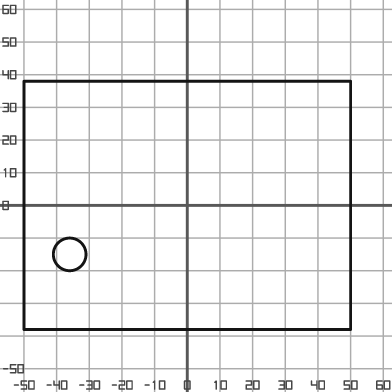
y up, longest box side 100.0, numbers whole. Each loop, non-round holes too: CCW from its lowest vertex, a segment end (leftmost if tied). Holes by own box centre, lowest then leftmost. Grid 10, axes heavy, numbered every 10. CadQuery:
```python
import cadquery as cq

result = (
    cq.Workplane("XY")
    .moveTo(-50.0, -38.0)
    .lineTo(50.0, -38.0)
    .lineTo(50.0, 38.0)
    .lineTo(-50.0, 38.0)
    .close()
    .moveTo(-36.0, -15.0)
    .circle(5.0)
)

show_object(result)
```